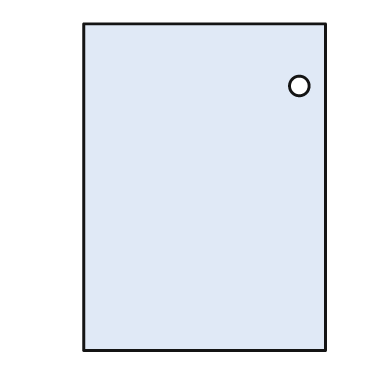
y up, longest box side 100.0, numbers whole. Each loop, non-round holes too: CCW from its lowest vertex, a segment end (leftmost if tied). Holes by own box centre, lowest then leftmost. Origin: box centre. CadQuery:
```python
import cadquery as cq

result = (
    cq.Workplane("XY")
    .moveTo(-37.0, -50.0)
    .lineTo(37.0, -50.0)
    .lineTo(37.0, 50.0)
    .lineTo(-37.0, 50.0)
    .close()
    .moveTo(29.0, 31.0)
    .circle(3.0)
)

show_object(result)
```